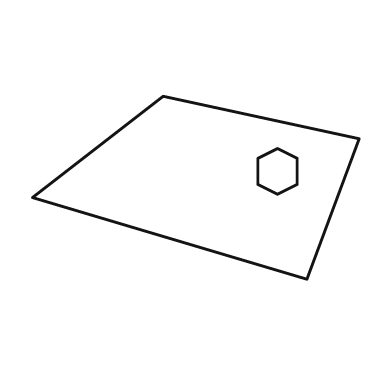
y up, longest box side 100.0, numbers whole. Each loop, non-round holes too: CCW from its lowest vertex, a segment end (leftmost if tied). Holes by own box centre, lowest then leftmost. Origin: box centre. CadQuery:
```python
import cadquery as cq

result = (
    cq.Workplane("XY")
    .moveTo(34.0, -28.0)
    .lineTo(50.0, 15.0)
    .lineTo(-10.0, 28.0)
    .lineTo(-50.0, -3.0)
    .close()
    .moveTo(25.0, -2.0)
    .lineTo(31.0, 1.0)
    .lineTo(31.0, 9.0)
    .lineTo(25.0, 12.0)
    .lineTo(19.0, 9.0)
    .lineTo(19.0, 1.0)
    .close()
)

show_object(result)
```